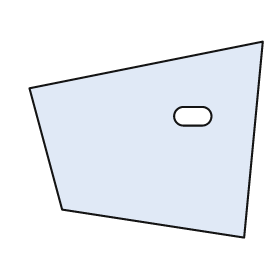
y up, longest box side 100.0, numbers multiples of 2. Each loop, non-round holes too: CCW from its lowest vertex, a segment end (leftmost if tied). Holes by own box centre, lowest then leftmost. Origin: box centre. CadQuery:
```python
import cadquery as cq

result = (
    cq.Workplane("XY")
    .moveTo(42.0, -42.0)
    .lineTo(50.0, 42.0)
    .lineTo(-50.0, 22.0)
    .lineTo(-36.0, -30.0)
    .close()
    .moveTo(16.0, 6.0)
    .lineTo(24.0, 6.0)
    .threePointArc((28.0, 10.0), (24.0, 14.0))
    .lineTo(16.0, 14.0)
    .threePointArc((12.0, 10.0), (16.0, 6.0))
    .close()
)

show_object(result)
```